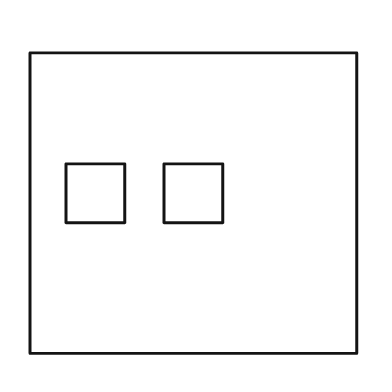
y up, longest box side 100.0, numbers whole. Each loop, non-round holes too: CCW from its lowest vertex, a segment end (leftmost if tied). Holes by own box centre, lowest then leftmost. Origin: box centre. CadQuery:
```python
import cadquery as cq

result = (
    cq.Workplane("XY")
    .moveTo(-50.0, -46.0)
    .lineTo(50.0, -46.0)
    .lineTo(50.0, 46.0)
    .lineTo(-50.0, 46.0)
    .close()
    .moveTo(-39.0, -6.0)
    .lineTo(-21.0, -6.0)
    .lineTo(-21.0, 12.0)
    .lineTo(-39.0, 12.0)
    .close()
    .moveTo(-9.0, -6.0)
    .lineTo(9.0, -6.0)
    .lineTo(9.0, 12.0)
    .lineTo(-9.0, 12.0)
    .close()
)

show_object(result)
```